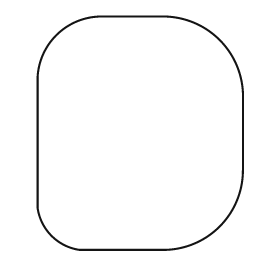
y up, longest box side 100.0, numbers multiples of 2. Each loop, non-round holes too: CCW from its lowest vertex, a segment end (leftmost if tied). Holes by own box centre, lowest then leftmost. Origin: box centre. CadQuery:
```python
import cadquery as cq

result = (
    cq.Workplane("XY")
    .moveTo(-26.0, -50.0)
    .lineTo(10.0, -50.0)
    .threePointArc((34.0, -40.0), (44.0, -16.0))
    .lineTo(44.0, 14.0)
    .threePointArc((34.0, 40.0), (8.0, 50.0))
    .lineTo(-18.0, 50.0)
    .threePointArc((-36.0, 42.0), (-44.0, 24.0))
    .lineTo(-44.0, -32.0)
    .threePointArc((-38.0, -44.0), (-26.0, -50.0))
    .close()
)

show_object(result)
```